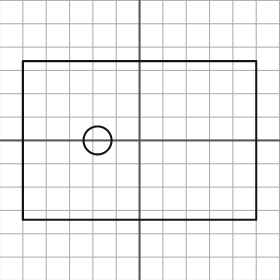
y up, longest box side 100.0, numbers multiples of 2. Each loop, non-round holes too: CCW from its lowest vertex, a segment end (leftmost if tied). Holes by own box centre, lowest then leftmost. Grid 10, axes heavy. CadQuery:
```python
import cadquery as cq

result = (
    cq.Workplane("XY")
    .moveTo(-50.0, -34.0)
    .lineTo(50.0, -34.0)
    .lineTo(50.0, 34.0)
    .lineTo(-50.0, 34.0)
    .close()
    .moveTo(-18.0, 0.0)
    .circle(6.0)
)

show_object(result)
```